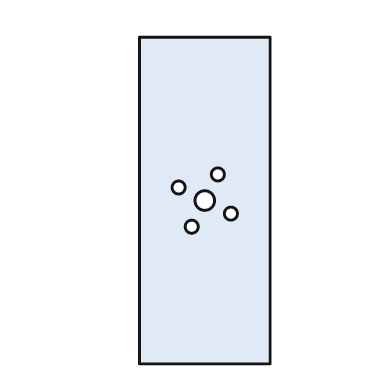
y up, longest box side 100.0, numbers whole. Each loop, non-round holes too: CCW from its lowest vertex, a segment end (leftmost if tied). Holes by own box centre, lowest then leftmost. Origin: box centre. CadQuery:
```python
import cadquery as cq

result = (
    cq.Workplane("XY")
    .moveTo(-20.0, -50.0)
    .lineTo(20.0, -50.0)
    .lineTo(20.0, 50.0)
    .lineTo(-20.0, 50.0)
    .close()
    .moveTo(-4.0, -8.0)
    .circle(2.0)
    .moveTo(8.0, -4.0)
    .circle(2.0)
    .moveTo(0.0, 0.0)
    .circle(3.0)
    .moveTo(-8.0, 4.0)
    .circle(2.0)
    .moveTo(4.0, 8.0)
    .circle(2.0)
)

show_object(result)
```